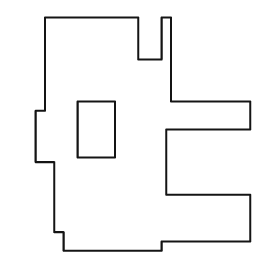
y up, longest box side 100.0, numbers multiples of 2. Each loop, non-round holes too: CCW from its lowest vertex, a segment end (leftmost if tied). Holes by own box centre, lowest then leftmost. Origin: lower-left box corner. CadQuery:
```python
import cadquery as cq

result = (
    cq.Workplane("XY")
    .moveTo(12.0, 0.0)
    .lineTo(54.0, 0.0)
    .lineTo(54.0, 4.0)
    .lineTo(92.0, 4.0)
    .lineTo(92.0, 24.0)
    .lineTo(56.0, 24.0)
    .lineTo(56.0, 52.0)
    .lineTo(92.0, 52.0)
    .lineTo(92.0, 64.0)
    .lineTo(58.0, 64.0)
    .lineTo(58.0, 100.0)
    .lineTo(54.0, 100.0)
    .lineTo(54.0, 82.0)
    .lineTo(44.0, 82.0)
    .lineTo(44.0, 100.0)
    .lineTo(4.0, 100.0)
    .lineTo(4.0, 60.0)
    .lineTo(0.0, 60.0)
    .lineTo(0.0, 38.0)
    .lineTo(8.0, 38.0)
    .lineTo(8.0, 8.0)
    .lineTo(12.0, 8.0)
    .close()
    .moveTo(18.0, 40.0)
    .lineTo(34.0, 40.0)
    .lineTo(34.0, 64.0)
    .lineTo(18.0, 64.0)
    .close()
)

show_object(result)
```